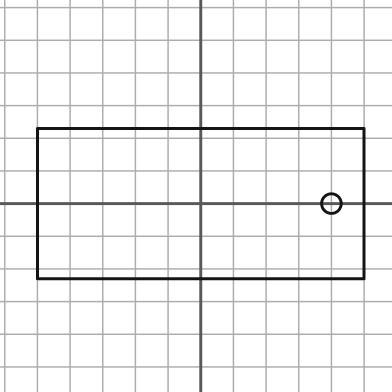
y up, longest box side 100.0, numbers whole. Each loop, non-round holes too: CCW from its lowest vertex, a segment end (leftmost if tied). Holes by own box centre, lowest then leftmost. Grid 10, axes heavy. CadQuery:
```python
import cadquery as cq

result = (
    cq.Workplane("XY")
    .moveTo(-50.0, -23.0)
    .lineTo(50.0, -23.0)
    .lineTo(50.0, 23.0)
    .lineTo(-50.0, 23.0)
    .close()
    .moveTo(40.0, 0.0)
    .circle(3.0)
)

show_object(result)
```